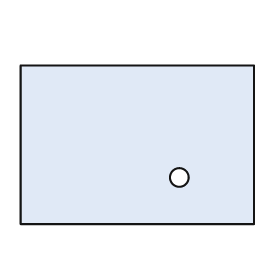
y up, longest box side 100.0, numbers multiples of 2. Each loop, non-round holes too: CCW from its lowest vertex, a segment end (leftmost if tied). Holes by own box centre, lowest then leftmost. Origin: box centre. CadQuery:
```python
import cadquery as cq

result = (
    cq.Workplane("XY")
    .moveTo(-50.0, -34.0)
    .lineTo(50.0, -34.0)
    .lineTo(50.0, 34.0)
    .lineTo(-50.0, 34.0)
    .close()
    .moveTo(18.0, -14.0)
    .circle(4.0)
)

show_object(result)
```